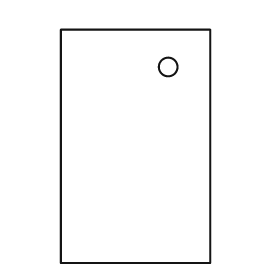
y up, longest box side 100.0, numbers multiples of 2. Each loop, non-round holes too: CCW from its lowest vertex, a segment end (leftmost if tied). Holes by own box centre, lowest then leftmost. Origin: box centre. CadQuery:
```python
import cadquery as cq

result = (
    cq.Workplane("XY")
    .moveTo(-32.0, -50.0)
    .lineTo(32.0, -50.0)
    .lineTo(32.0, 50.0)
    .lineTo(-32.0, 50.0)
    .close()
    .moveTo(14.0, 34.0)
    .circle(4.0)
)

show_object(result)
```